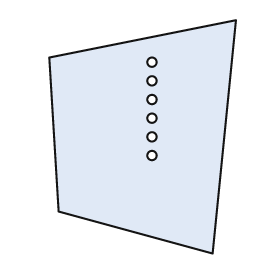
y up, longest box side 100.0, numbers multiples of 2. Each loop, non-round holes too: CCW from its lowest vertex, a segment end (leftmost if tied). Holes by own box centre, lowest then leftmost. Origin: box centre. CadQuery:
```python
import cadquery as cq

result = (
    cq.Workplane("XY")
    .moveTo(30.0, -50.0)
    .lineTo(40.0, 50.0)
    .lineTo(-40.0, 34.0)
    .lineTo(-36.0, -32.0)
    .close()
    .moveTo(4.0, -8.0)
    .circle(2.0)
    .moveTo(4.0, 0.0)
    .circle(2.0)
    .moveTo(4.0, 8.0)
    .circle(2.0)
    .moveTo(4.0, 16.0)
    .circle(2.0)
    .moveTo(4.0, 24.0)
    .circle(2.0)
    .moveTo(4.0, 32.0)
    .circle(2.0)
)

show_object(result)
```